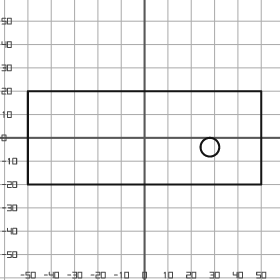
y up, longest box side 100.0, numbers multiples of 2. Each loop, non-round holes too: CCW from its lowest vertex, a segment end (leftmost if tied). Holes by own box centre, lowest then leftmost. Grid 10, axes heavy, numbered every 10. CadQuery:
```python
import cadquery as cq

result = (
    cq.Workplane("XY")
    .moveTo(-50.0, -20.0)
    .lineTo(50.0, -20.0)
    .lineTo(50.0, 20.0)
    .lineTo(-50.0, 20.0)
    .close()
    .moveTo(28.0, -4.0)
    .circle(4.0)
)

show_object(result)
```